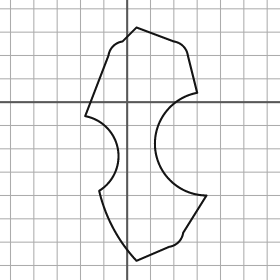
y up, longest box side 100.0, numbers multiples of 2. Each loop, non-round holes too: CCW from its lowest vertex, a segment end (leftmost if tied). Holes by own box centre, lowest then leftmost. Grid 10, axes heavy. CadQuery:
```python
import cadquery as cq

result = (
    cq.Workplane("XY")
    .moveTo(4.0, -68.0)
    .lineTo(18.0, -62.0)
    .threePointArc((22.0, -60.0), (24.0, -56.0))
    .lineTo(34.0, -40.0)
    .threePointArc((12.0, -20.0), (30.0, 4.0))
    .lineTo(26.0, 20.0)
    .threePointArc((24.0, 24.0), (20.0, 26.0))
    .lineTo(4.0, 32.0)
    .lineTo(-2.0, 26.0)
    .threePointArc((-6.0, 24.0), (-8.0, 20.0))
    .lineTo(-18.0, -6.0)
    .threePointArc((-4.0, -20.0), (-12.0, -38.0))
    .threePointArc((-6.0, -54.0), (4.0, -68.0))
    .close()
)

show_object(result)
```